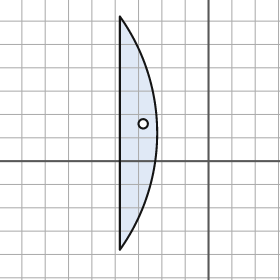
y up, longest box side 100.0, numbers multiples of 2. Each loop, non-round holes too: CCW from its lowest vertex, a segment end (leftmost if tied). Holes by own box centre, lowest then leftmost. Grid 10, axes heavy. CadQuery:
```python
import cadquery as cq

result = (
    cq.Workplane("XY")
    .moveTo(-38.0, -38.0)
    .threePointArc((-22.0, 12.0), (-38.0, 62.0))
    .close()
    .moveTo(-28.0, 16.0)
    .circle(2.0)
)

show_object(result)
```